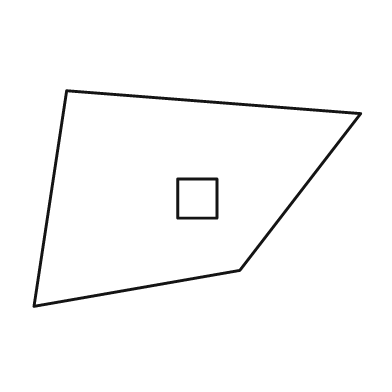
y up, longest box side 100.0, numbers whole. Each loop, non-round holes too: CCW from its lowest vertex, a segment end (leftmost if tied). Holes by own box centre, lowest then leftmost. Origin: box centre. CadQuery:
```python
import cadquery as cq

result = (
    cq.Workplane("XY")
    .moveTo(-50.0, -33.0)
    .lineTo(13.0, -22.0)
    .lineTo(50.0, 26.0)
    .lineTo(-40.0, 33.0)
    .close()
    .moveTo(-6.0, -6.0)
    .lineTo(6.0, -6.0)
    .lineTo(6.0, 6.0)
    .lineTo(-6.0, 6.0)
    .close()
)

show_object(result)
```